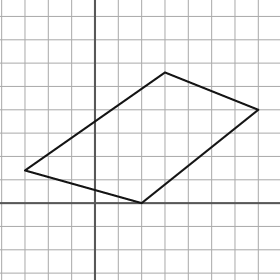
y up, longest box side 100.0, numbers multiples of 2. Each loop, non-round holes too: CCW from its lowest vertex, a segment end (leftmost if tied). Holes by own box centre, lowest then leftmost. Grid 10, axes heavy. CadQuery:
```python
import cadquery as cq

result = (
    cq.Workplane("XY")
    .moveTo(20.0, 0.0)
    .lineTo(70.0, 40.0)
    .lineTo(30.0, 56.0)
    .lineTo(-30.0, 14.0)
    .close()
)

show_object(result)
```